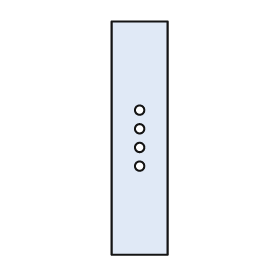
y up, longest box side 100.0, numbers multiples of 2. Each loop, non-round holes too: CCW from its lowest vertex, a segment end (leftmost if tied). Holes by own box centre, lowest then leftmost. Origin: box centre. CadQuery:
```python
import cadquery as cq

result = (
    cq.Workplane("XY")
    .moveTo(-12.0, -50.0)
    .lineTo(12.0, -50.0)
    .lineTo(12.0, 50.0)
    .lineTo(-12.0, 50.0)
    .close()
    .moveTo(0.0, -12.0)
    .circle(2.0)
    .moveTo(0.0, -4.0)
    .circle(2.0)
    .moveTo(0.0, 4.0)
    .circle(2.0)
    .moveTo(0.0, 12.0)
    .circle(2.0)
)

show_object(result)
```